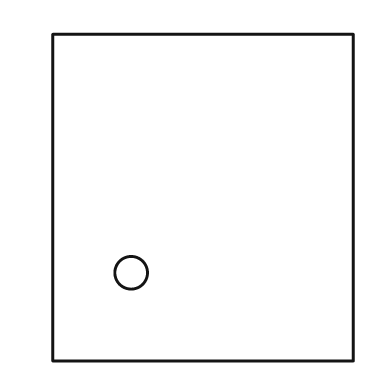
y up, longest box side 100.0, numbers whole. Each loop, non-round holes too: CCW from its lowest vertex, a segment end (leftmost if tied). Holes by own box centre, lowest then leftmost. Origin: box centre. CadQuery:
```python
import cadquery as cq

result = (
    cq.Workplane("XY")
    .moveTo(-46.0, -50.0)
    .lineTo(46.0, -50.0)
    .lineTo(46.0, 50.0)
    .lineTo(-46.0, 50.0)
    .close()
    .moveTo(-22.0, -23.0)
    .circle(5.0)
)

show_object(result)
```